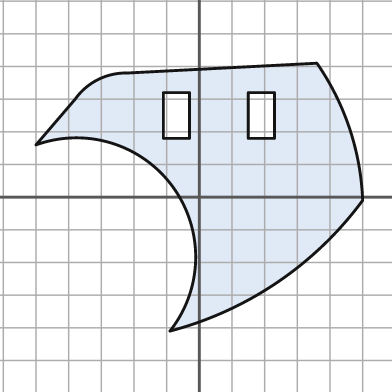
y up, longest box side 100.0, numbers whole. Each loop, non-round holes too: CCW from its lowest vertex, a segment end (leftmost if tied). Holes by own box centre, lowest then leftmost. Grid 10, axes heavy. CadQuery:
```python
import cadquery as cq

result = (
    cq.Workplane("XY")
    .moveTo(-9.0, -41.0)
    .threePointArc((24.0, -26.0), (50.0, -1.0))
    .threePointArc((46.0, 21.0), (36.0, 41.0))
    .lineTo(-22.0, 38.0)
    .threePointArc((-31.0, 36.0), (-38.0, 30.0))
    .lineTo(-50.0, 16.0)
    .threePointArc((-8.0, 3.0), (-9.0, -41.0))
    .close()
    .moveTo(-11.0, 18.0)
    .lineTo(-3.0, 18.0)
    .lineTo(-3.0, 32.0)
    .lineTo(-11.0, 32.0)
    .close()
    .moveTo(15.0, 18.0)
    .lineTo(23.0, 18.0)
    .lineTo(23.0, 32.0)
    .lineTo(15.0, 32.0)
    .close()
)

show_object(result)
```